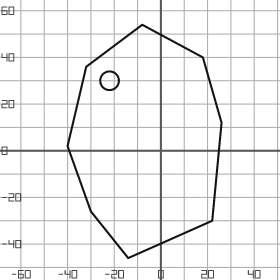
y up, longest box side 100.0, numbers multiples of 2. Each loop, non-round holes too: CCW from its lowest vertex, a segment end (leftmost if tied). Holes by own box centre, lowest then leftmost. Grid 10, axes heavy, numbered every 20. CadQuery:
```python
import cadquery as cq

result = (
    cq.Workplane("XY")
    .moveTo(-14.0, -46.0)
    .lineTo(22.0, -30.0)
    .lineTo(26.0, 12.0)
    .lineTo(18.0, 40.0)
    .lineTo(-8.0, 54.0)
    .lineTo(-32.0, 36.0)
    .lineTo(-40.0, 2.0)
    .lineTo(-30.0, -26.0)
    .close()
    .moveTo(-22.0, 30.0)
    .circle(4.0)
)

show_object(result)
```